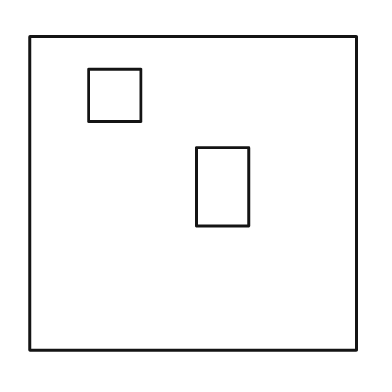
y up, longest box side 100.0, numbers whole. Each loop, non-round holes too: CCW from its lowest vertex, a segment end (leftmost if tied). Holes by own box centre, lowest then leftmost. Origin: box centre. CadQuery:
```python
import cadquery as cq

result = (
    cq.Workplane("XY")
    .moveTo(-50.0, -48.0)
    .lineTo(50.0, -48.0)
    .lineTo(50.0, 48.0)
    .lineTo(-50.0, 48.0)
    .close()
    .moveTo(1.0, -10.0)
    .lineTo(17.0, -10.0)
    .lineTo(17.0, 14.0)
    .lineTo(1.0, 14.0)
    .close()
    .moveTo(-32.0, 22.0)
    .lineTo(-16.0, 22.0)
    .lineTo(-16.0, 38.0)
    .lineTo(-32.0, 38.0)
    .close()
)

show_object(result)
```